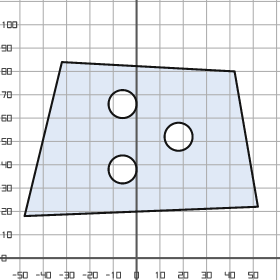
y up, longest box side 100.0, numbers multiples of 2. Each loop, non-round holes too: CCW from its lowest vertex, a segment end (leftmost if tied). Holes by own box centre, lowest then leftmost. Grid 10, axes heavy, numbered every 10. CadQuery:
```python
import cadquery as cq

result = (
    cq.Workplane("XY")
    .moveTo(-48.0, 18.0)
    .lineTo(52.0, 22.0)
    .lineTo(42.0, 80.0)
    .lineTo(-32.0, 84.0)
    .close()
    .moveTo(-6.0, 38.0)
    .circle(6.0)
    .moveTo(18.0, 52.0)
    .circle(6.0)
    .moveTo(-6.0, 66.0)
    .circle(6.0)
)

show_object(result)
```